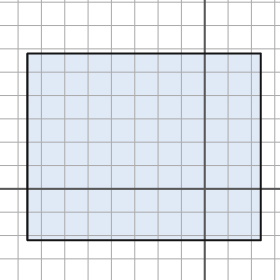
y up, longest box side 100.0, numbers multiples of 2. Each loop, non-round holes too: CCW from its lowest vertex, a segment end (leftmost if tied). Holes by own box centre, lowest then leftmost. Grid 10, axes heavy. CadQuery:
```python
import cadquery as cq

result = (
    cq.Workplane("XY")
    .moveTo(-76.0, -22.0)
    .lineTo(24.0, -22.0)
    .lineTo(24.0, 58.0)
    .lineTo(-76.0, 58.0)
    .close()
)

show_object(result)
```